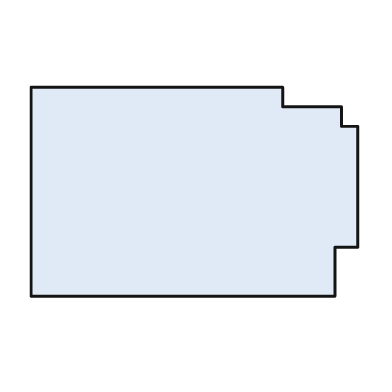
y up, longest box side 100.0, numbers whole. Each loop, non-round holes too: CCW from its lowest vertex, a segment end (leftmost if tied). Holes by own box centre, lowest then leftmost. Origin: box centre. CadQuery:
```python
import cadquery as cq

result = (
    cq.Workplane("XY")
    .moveTo(-50.0, -32.0)
    .lineTo(43.0, -32.0)
    .lineTo(43.0, -17.0)
    .lineTo(50.0, -17.0)
    .lineTo(50.0, 20.0)
    .lineTo(45.0, 20.0)
    .lineTo(45.0, 26.0)
    .lineTo(27.0, 26.0)
    .lineTo(27.0, 32.0)
    .lineTo(-50.0, 32.0)
    .close()
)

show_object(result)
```